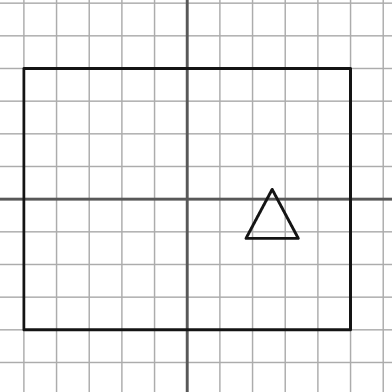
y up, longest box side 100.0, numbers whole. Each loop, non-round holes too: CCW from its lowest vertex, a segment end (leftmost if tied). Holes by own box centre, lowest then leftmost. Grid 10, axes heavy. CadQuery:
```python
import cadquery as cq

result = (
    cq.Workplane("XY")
    .moveTo(-50.0, -40.0)
    .lineTo(50.0, -40.0)
    .lineTo(50.0, 40.0)
    .lineTo(-50.0, 40.0)
    .close()
    .moveTo(18.0, -12.0)
    .lineTo(34.0, -12.0)
    .lineTo(26.0, 3.0)
    .close()
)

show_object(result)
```